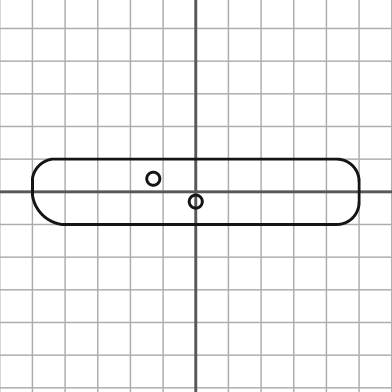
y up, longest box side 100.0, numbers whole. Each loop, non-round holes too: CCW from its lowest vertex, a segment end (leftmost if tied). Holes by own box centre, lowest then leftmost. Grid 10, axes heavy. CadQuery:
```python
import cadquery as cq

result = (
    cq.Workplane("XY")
    .moveTo(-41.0, -10.0)
    .lineTo(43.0, -10.0)
    .threePointArc((48.0, -8.0), (50.0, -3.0))
    .lineTo(50.0, 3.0)
    .threePointArc((48.0, 8.0), (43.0, 10.0))
    .lineTo(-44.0, 10.0)
    .threePointArc((-48.0, 8.0), (-50.0, 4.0))
    .lineTo(-50.0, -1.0)
    .threePointArc((-47.0, -7.0), (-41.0, -10.0))
    .close()
    .moveTo(0.0, -3.0)
    .circle(2.0)
    .moveTo(-13.0, 4.0)
    .circle(2.0)
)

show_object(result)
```